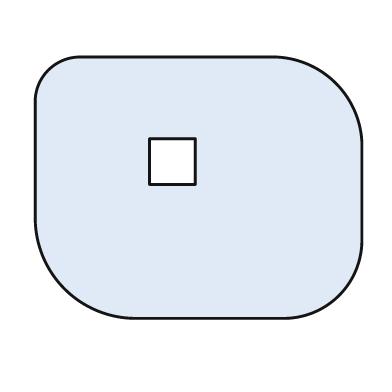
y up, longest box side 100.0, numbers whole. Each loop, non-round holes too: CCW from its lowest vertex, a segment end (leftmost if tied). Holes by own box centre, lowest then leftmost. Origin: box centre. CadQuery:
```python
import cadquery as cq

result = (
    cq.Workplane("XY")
    .moveTo(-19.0, -40.0)
    .lineTo(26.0, -40.0)
    .threePointArc((43.0, -33.0), (50.0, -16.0))
    .lineTo(50.0, 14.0)
    .threePointArc((42.0, 32.0), (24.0, 40.0))
    .lineTo(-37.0, 40.0)
    .threePointArc((-46.0, 36.0), (-50.0, 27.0))
    .lineTo(-50.0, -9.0)
    .threePointArc((-41.0, -31.0), (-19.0, -40.0))
    .close()
    .moveTo(-15.0, 1.0)
    .lineTo(-1.0, 1.0)
    .lineTo(-1.0, 15.0)
    .lineTo(-15.0, 15.0)
    .close()
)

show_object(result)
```